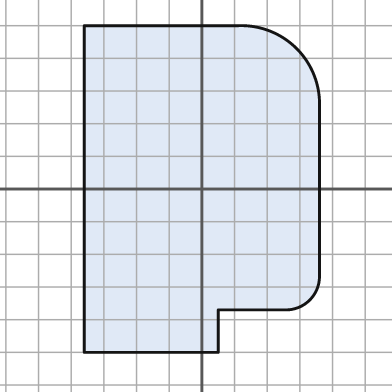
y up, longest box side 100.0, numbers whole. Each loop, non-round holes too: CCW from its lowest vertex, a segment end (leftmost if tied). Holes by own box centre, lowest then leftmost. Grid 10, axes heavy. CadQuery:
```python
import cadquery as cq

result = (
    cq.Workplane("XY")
    .moveTo(-36.0, -50.0)
    .lineTo(5.0, -50.0)
    .lineTo(5.0, -37.0)
    .lineTo(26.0, -37.0)
    .threePointArc((33.0, -34.0), (36.0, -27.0))
    .lineTo(36.0, 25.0)
    .threePointArc((29.0, 43.0), (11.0, 50.0))
    .lineTo(-36.0, 50.0)
    .close()
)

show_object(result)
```